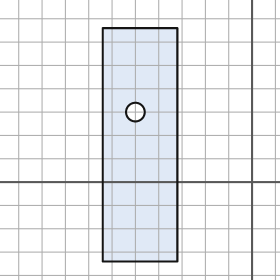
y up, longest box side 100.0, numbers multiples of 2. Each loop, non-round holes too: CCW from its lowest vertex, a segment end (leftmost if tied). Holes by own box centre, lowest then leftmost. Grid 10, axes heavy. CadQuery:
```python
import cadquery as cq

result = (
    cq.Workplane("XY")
    .moveTo(-64.0, -34.0)
    .lineTo(-32.0, -34.0)
    .lineTo(-32.0, 66.0)
    .lineTo(-64.0, 66.0)
    .close()
    .moveTo(-50.0, 30.0)
    .circle(4.0)
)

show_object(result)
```